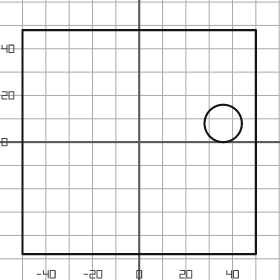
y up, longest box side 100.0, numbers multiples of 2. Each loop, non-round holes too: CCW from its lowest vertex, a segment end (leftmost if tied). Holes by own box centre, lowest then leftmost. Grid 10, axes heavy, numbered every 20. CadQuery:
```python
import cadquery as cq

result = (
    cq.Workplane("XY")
    .moveTo(-50.0, -48.0)
    .lineTo(50.0, -48.0)
    .lineTo(50.0, 48.0)
    .lineTo(-50.0, 48.0)
    .close()
    .moveTo(36.0, 8.0)
    .circle(8.0)
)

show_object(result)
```